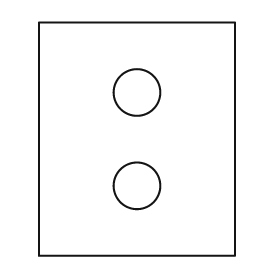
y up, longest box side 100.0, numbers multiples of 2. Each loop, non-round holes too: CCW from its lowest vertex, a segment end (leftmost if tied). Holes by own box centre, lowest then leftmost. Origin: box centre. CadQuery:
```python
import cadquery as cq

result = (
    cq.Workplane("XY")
    .moveTo(-42.0, -50.0)
    .lineTo(42.0, -50.0)
    .lineTo(42.0, 50.0)
    .lineTo(-42.0, 50.0)
    .close()
    .moveTo(0.0, -20.0)
    .circle(10.0)
    .moveTo(0.0, 20.0)
    .circle(10.0)
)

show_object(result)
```